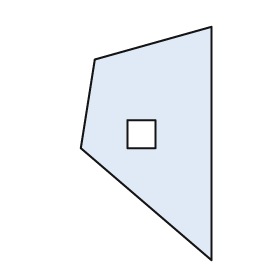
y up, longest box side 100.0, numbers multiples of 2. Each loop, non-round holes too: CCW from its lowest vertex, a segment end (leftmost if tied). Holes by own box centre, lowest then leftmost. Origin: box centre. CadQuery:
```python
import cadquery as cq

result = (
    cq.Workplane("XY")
    .moveTo(28.0, -50.0)
    .lineTo(28.0, 50.0)
    .lineTo(-22.0, 36.0)
    .lineTo(-28.0, -2.0)
    .close()
    .moveTo(-8.0, -2.0)
    .lineTo(4.0, -2.0)
    .lineTo(4.0, 10.0)
    .lineTo(-8.0, 10.0)
    .close()
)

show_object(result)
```